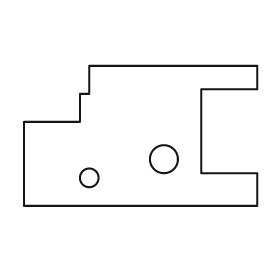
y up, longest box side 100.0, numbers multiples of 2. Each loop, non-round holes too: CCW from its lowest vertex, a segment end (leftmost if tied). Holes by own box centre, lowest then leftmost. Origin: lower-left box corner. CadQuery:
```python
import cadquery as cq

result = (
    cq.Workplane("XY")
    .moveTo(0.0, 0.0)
    .lineTo(100.0, 0.0)
    .lineTo(100.0, 14.0)
    .lineTo(76.0, 14.0)
    .lineTo(76.0, 50.0)
    .lineTo(100.0, 50.0)
    .lineTo(100.0, 60.0)
    .lineTo(28.0, 60.0)
    .lineTo(28.0, 48.0)
    .lineTo(24.0, 48.0)
    .lineTo(24.0, 36.0)
    .lineTo(0.0, 36.0)
    .close()
    .moveTo(28.0, 12.0)
    .circle(4.0)
    .moveTo(60.0, 20.0)
    .circle(6.0)
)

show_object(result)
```